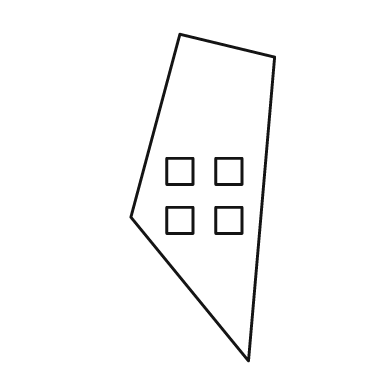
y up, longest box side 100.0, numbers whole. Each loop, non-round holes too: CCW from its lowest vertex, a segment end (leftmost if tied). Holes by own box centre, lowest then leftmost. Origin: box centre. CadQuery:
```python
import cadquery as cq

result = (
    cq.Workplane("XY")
    .moveTo(14.0, -50.0)
    .lineTo(22.0, 43.0)
    .lineTo(-7.0, 50.0)
    .lineTo(-22.0, -6.0)
    .close()
    .moveTo(-11.0, -11.0)
    .lineTo(-3.0, -11.0)
    .lineTo(-3.0, -3.0)
    .lineTo(-11.0, -3.0)
    .close()
    .moveTo(4.0, -11.0)
    .lineTo(12.0, -11.0)
    .lineTo(12.0, -3.0)
    .lineTo(4.0, -3.0)
    .close()
    .moveTo(-11.0, 4.0)
    .lineTo(-3.0, 4.0)
    .lineTo(-3.0, 12.0)
    .lineTo(-11.0, 12.0)
    .close()
    .moveTo(4.0, 4.0)
    .lineTo(12.0, 4.0)
    .lineTo(12.0, 12.0)
    .lineTo(4.0, 12.0)
    .close()
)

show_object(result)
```